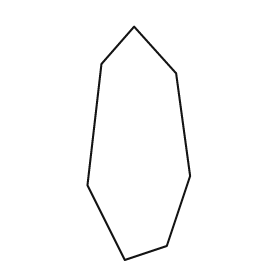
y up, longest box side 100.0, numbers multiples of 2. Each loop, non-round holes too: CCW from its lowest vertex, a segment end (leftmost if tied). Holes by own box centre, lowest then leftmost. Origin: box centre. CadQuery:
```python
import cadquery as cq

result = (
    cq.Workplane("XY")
    .moveTo(-6.0, -50.0)
    .lineTo(12.0, -44.0)
    .lineTo(22.0, -14.0)
    .lineTo(16.0, 30.0)
    .lineTo(-2.0, 50.0)
    .lineTo(-16.0, 34.0)
    .lineTo(-22.0, -18.0)
    .close()
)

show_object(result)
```